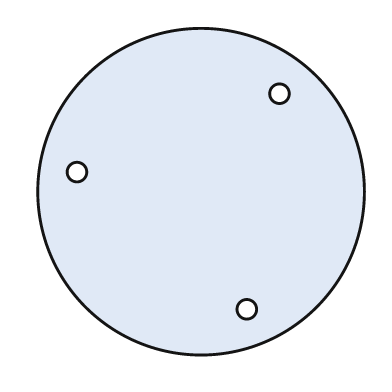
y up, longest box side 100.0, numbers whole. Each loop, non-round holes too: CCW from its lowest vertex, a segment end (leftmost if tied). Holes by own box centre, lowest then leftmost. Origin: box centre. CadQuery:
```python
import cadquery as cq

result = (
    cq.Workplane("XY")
    .moveTo(0.0, 0.0)
    .circle(50.0)
    .moveTo(14.0, -36.0)
    .circle(3.0)
    .moveTo(-38.0, 6.0)
    .circle(3.0)
    .moveTo(24.0, 30.0)
    .circle(3.0)
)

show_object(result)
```